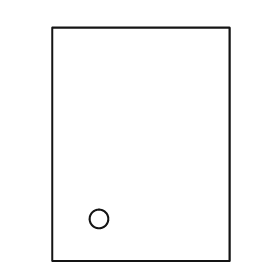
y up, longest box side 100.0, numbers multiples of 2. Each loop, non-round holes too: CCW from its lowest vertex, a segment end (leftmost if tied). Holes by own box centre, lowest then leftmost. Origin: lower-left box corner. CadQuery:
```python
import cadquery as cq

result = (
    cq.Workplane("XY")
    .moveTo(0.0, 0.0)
    .lineTo(76.0, 0.0)
    .lineTo(76.0, 100.0)
    .lineTo(0.0, 100.0)
    .close()
    .moveTo(20.0, 18.0)
    .circle(4.0)
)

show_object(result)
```